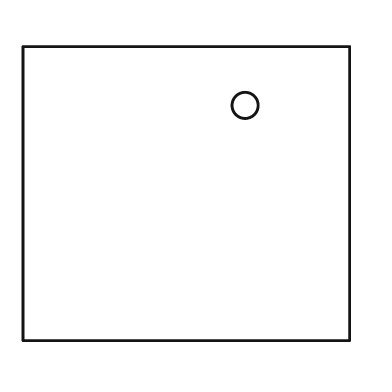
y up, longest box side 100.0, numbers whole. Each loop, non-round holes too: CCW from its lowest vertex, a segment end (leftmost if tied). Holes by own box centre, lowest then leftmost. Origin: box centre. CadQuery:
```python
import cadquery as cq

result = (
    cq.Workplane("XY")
    .moveTo(-50.0, -45.0)
    .lineTo(50.0, -45.0)
    .lineTo(50.0, 45.0)
    .lineTo(-50.0, 45.0)
    .close()
    .moveTo(18.0, 27.0)
    .circle(4.0)
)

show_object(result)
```